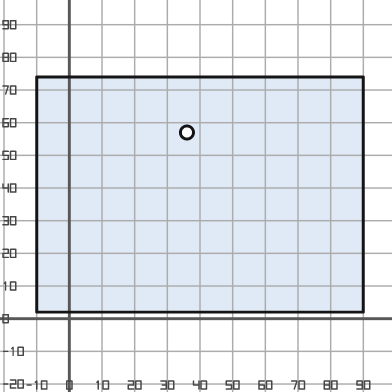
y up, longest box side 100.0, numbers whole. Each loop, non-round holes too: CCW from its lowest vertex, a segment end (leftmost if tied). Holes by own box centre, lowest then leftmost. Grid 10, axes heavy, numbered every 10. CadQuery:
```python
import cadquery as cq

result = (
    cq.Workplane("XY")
    .moveTo(-10.0, 2.0)
    .lineTo(90.0, 2.0)
    .lineTo(90.0, 74.0)
    .lineTo(-10.0, 74.0)
    .close()
    .moveTo(36.0, 57.0)
    .circle(2.0)
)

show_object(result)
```